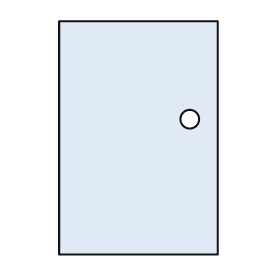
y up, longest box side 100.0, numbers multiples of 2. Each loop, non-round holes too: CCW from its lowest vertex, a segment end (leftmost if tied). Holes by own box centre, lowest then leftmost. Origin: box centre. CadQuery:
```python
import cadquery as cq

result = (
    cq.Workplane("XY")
    .moveTo(-34.0, -50.0)
    .lineTo(34.0, -50.0)
    .lineTo(34.0, 50.0)
    .lineTo(-34.0, 50.0)
    .close()
    .moveTo(22.0, 8.0)
    .circle(4.0)
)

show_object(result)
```